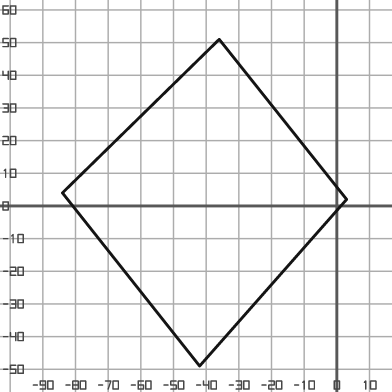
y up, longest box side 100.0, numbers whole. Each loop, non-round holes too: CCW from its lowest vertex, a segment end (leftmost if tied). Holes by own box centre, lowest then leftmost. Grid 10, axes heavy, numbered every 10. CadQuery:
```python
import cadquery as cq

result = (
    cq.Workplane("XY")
    .moveTo(-42.0, -49.0)
    .lineTo(3.0, 2.0)
    .lineTo(-36.0, 51.0)
    .lineTo(-84.0, 4.0)
    .close()
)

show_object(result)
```